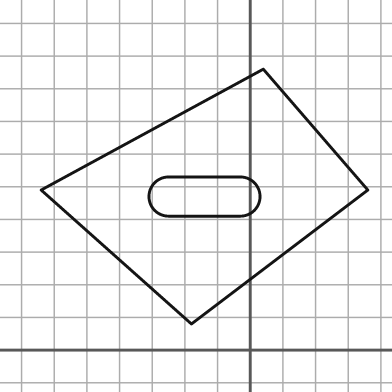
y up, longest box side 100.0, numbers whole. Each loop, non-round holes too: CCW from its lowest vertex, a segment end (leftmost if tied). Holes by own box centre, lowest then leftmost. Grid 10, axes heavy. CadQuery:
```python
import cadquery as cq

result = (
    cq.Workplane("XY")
    .moveTo(-18.0, 8.0)
    .lineTo(36.0, 49.0)
    .lineTo(4.0, 86.0)
    .lineTo(-64.0, 49.0)
    .close()
    .moveTo(-25.0, 41.0)
    .lineTo(-3.0, 41.0)
    .threePointArc((3.0, 47.0), (-3.0, 53.0))
    .lineTo(-25.0, 53.0)
    .threePointArc((-31.0, 47.0), (-25.0, 41.0))
    .close()
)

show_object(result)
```